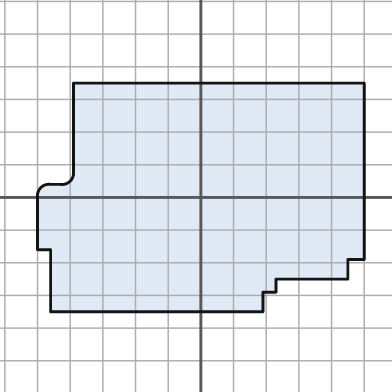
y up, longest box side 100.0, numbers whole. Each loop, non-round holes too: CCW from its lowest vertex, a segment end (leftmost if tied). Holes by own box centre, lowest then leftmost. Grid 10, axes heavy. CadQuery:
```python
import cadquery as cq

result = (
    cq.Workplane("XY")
    .moveTo(-46.0, -35.0)
    .lineTo(19.0, -35.0)
    .lineTo(19.0, -29.0)
    .lineTo(23.0, -29.0)
    .lineTo(23.0, -25.0)
    .lineTo(45.0, -25.0)
    .lineTo(45.0, -19.0)
    .lineTo(50.0, -19.0)
    .lineTo(50.0, 35.0)
    .lineTo(-39.0, 35.0)
    .lineTo(-39.0, 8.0)
    .threePointArc((-40.0, 5.0), (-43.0, 4.0))
    .lineTo(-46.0, 4.0)
    .threePointArc((-49.0, 3.0), (-50.0, 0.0))
    .lineTo(-50.0, -16.0)
    .lineTo(-46.0, -16.0)
    .close()
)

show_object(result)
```